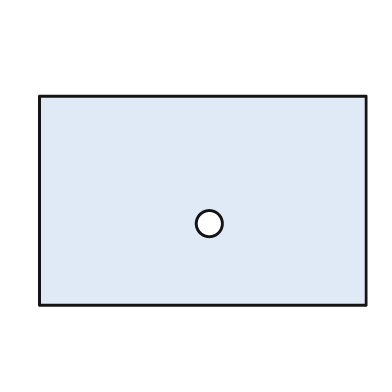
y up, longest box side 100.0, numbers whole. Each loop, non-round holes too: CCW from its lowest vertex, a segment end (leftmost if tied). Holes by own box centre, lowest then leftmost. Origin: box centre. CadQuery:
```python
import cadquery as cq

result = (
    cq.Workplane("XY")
    .moveTo(-50.0, -32.0)
    .lineTo(50.0, -32.0)
    .lineTo(50.0, 32.0)
    .lineTo(-50.0, 32.0)
    .close()
    .moveTo(2.0, -7.0)
    .circle(4.0)
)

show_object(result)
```